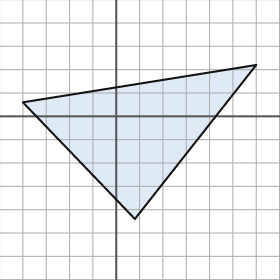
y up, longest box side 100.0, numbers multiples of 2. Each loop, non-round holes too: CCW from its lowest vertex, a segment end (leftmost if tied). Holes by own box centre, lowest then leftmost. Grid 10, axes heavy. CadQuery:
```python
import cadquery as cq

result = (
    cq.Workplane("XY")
    .moveTo(8.0, -44.0)
    .lineTo(60.0, 22.0)
    .lineTo(-40.0, 6.0)
    .close()
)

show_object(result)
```